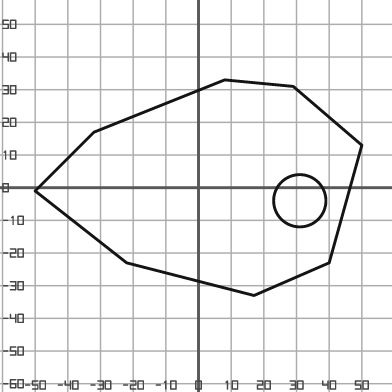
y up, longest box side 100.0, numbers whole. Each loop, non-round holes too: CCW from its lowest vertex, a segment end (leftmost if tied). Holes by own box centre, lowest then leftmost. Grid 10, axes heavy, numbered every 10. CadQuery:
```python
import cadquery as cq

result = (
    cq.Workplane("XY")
    .moveTo(17.0, -33.0)
    .lineTo(40.0, -23.0)
    .lineTo(50.0, 13.0)
    .lineTo(29.0, 31.0)
    .lineTo(8.0, 33.0)
    .lineTo(-32.0, 17.0)
    .lineTo(-50.0, -1.0)
    .lineTo(-22.0, -23.0)
    .close()
    .moveTo(31.0, -4.0)
    .circle(8.0)
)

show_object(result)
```